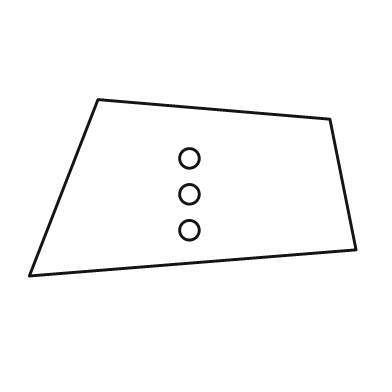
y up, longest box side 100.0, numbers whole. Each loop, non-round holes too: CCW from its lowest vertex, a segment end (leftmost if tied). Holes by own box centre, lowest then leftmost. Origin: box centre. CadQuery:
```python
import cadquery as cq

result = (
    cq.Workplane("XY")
    .moveTo(-50.0, -27.0)
    .lineTo(50.0, -19.0)
    .lineTo(42.0, 21.0)
    .lineTo(-29.0, 27.0)
    .close()
    .moveTo(-1.0, -13.0)
    .circle(3.0)
    .moveTo(-1.0, -2.0)
    .circle(3.0)
    .moveTo(-1.0, 9.0)
    .circle(3.0)
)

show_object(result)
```